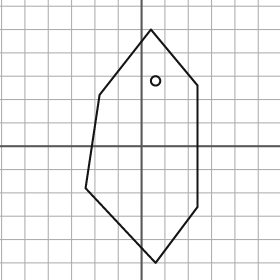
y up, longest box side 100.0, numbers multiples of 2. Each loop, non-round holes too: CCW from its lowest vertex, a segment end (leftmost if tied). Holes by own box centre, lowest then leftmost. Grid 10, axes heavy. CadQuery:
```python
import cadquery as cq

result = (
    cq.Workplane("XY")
    .moveTo(6.0, -50.0)
    .lineTo(24.0, -26.0)
    .lineTo(24.0, 26.0)
    .lineTo(4.0, 50.0)
    .lineTo(-18.0, 22.0)
    .lineTo(-24.0, -18.0)
    .close()
    .moveTo(6.0, 28.0)
    .circle(2.0)
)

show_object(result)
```